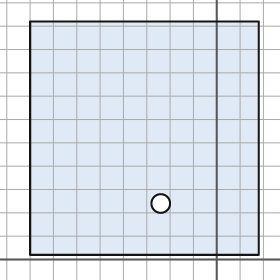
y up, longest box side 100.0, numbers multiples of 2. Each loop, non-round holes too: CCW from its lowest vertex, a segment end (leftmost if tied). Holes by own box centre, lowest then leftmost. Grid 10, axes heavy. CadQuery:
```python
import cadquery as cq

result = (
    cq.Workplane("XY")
    .moveTo(-80.0, 2.0)
    .lineTo(18.0, 2.0)
    .lineTo(18.0, 102.0)
    .lineTo(-80.0, 102.0)
    .close()
    .moveTo(-24.0, 24.0)
    .circle(4.0)
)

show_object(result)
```